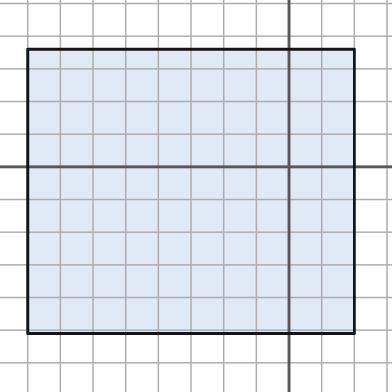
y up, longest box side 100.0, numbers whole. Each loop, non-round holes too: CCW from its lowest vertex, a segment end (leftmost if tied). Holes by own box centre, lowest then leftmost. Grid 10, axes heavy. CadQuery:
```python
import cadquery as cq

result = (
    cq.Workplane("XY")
    .moveTo(-80.0, -51.0)
    .lineTo(20.0, -51.0)
    .lineTo(20.0, 36.0)
    .lineTo(-80.0, 36.0)
    .close()
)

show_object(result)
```